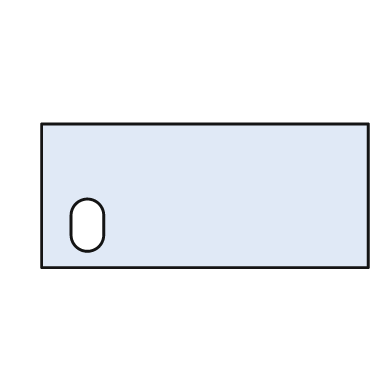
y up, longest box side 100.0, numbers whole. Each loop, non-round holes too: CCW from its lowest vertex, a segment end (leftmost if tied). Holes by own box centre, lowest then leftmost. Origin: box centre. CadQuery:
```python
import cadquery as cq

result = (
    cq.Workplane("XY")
    .moveTo(-50.0, -22.0)
    .lineTo(50.0, -22.0)
    .lineTo(50.0, 22.0)
    .lineTo(-50.0, 22.0)
    .close()
    .moveTo(-41.0, -12.0)
    .threePointArc((-36.0, -17.0), (-31.0, -12.0))
    .lineTo(-31.0, -6.0)
    .threePointArc((-36.0, -1.0), (-41.0, -6.0))
    .close()
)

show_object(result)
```